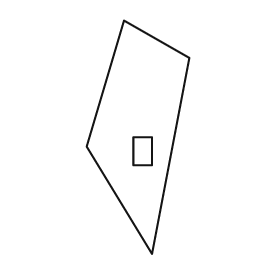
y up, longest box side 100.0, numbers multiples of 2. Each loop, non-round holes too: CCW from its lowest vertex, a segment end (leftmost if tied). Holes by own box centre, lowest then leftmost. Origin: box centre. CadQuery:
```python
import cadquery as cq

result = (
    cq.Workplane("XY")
    .moveTo(6.0, -50.0)
    .lineTo(22.0, 34.0)
    .lineTo(-6.0, 50.0)
    .lineTo(-22.0, -4.0)
    .close()
    .moveTo(-2.0, -12.0)
    .lineTo(6.0, -12.0)
    .lineTo(6.0, 0.0)
    .lineTo(-2.0, 0.0)
    .close()
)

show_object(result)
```